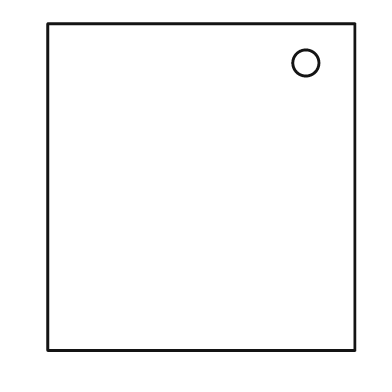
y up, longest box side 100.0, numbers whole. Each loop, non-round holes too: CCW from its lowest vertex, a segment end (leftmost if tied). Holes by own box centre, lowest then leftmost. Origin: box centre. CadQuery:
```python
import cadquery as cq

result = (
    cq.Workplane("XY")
    .moveTo(-47.0, -50.0)
    .lineTo(47.0, -50.0)
    .lineTo(47.0, 50.0)
    .lineTo(-47.0, 50.0)
    .close()
    .moveTo(32.0, 38.0)
    .circle(4.0)
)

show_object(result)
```